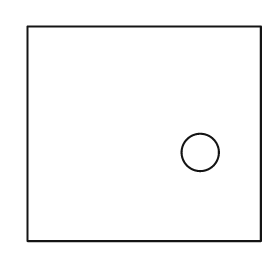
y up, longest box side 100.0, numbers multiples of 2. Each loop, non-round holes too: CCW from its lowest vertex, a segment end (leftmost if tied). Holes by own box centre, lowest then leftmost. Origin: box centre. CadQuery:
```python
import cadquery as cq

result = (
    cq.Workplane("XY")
    .moveTo(-50.0, -46.0)
    .lineTo(50.0, -46.0)
    .lineTo(50.0, 46.0)
    .lineTo(-50.0, 46.0)
    .close()
    .moveTo(24.0, -8.0)
    .circle(8.0)
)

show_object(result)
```